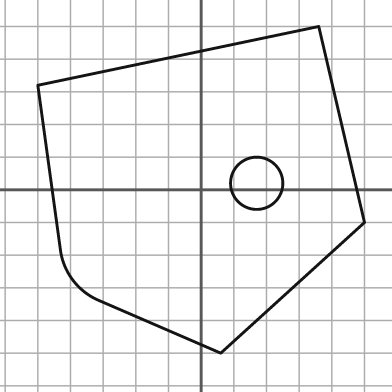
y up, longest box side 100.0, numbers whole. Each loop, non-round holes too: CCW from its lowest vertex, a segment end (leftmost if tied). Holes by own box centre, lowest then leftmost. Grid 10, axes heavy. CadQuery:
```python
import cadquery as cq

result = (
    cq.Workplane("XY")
    .moveTo(6.0, -50.0)
    .lineTo(50.0, -10.0)
    .lineTo(36.0, 50.0)
    .lineTo(-50.0, 32.0)
    .lineTo(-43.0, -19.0)
    .threePointArc((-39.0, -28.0), (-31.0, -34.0))
    .close()
    .moveTo(17.0, 2.0)
    .circle(8.0)
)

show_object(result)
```